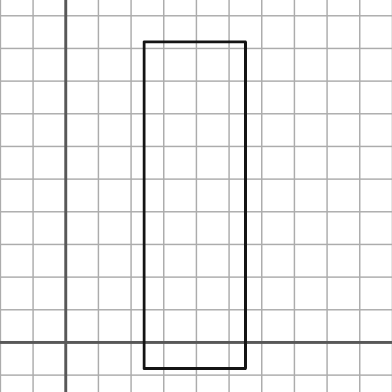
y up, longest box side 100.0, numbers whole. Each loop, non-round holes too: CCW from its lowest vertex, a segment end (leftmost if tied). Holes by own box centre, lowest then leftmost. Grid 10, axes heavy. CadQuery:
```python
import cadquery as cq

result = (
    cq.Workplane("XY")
    .moveTo(24.0, -8.0)
    .lineTo(55.0, -8.0)
    .lineTo(55.0, 92.0)
    .lineTo(24.0, 92.0)
    .close()
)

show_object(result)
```